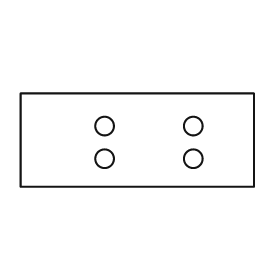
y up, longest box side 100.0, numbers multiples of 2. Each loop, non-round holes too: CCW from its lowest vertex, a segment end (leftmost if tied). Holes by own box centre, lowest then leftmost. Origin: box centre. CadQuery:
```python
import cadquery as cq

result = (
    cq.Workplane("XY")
    .moveTo(-50.0, -20.0)
    .lineTo(50.0, -20.0)
    .lineTo(50.0, 20.0)
    .lineTo(-50.0, 20.0)
    .close()
    .moveTo(-14.0, -8.0)
    .circle(4.0)
    .moveTo(24.0, -8.0)
    .circle(4.0)
    .moveTo(-14.0, 6.0)
    .circle(4.0)
    .moveTo(24.0, 6.0)
    .circle(4.0)
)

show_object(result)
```